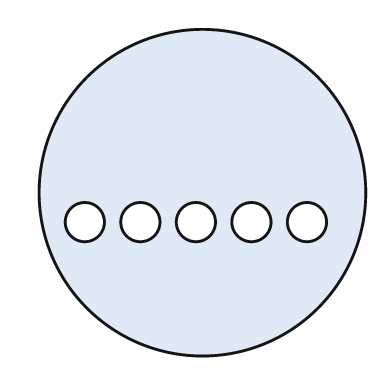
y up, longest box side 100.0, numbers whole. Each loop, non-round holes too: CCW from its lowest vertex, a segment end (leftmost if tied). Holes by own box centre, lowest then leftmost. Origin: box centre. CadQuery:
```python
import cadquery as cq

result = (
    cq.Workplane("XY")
    .moveTo(0.0, 0.0)
    .circle(50.0)
    .moveTo(-36.0, -9.0)
    .circle(6.0)
    .moveTo(-19.0, -9.0)
    .circle(6.0)
    .moveTo(-2.0, -9.0)
    .circle(6.0)
    .moveTo(15.0, -9.0)
    .circle(6.0)
    .moveTo(32.0, -9.0)
    .circle(6.0)
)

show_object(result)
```